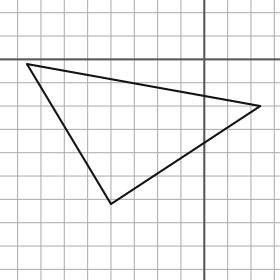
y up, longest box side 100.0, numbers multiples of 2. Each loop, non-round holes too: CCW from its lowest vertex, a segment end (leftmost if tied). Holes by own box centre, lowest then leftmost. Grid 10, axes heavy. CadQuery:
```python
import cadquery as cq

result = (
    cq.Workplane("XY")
    .moveTo(-40.0, -62.0)
    .lineTo(24.0, -20.0)
    .lineTo(-76.0, -2.0)
    .close()
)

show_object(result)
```